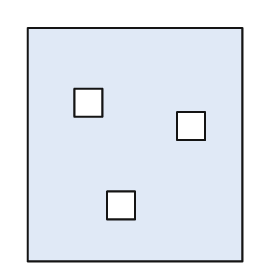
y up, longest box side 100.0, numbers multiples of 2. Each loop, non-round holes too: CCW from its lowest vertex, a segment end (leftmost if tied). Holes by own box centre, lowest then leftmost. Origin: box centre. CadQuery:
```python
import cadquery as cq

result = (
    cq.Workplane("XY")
    .moveTo(-46.0, -50.0)
    .lineTo(46.0, -50.0)
    .lineTo(46.0, 50.0)
    .lineTo(-46.0, 50.0)
    .close()
    .moveTo(-12.0, -32.0)
    .lineTo(0.0, -32.0)
    .lineTo(0.0, -20.0)
    .lineTo(-12.0, -20.0)
    .close()
    .moveTo(18.0, 2.0)
    .lineTo(30.0, 2.0)
    .lineTo(30.0, 14.0)
    .lineTo(18.0, 14.0)
    .close()
    .moveTo(-26.0, 12.0)
    .lineTo(-14.0, 12.0)
    .lineTo(-14.0, 24.0)
    .lineTo(-26.0, 24.0)
    .close()
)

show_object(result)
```